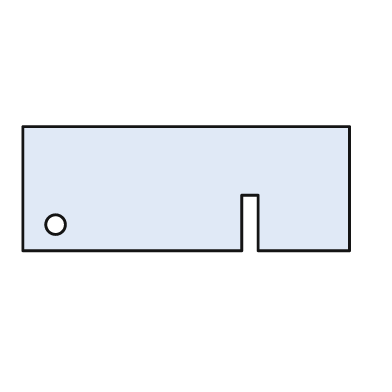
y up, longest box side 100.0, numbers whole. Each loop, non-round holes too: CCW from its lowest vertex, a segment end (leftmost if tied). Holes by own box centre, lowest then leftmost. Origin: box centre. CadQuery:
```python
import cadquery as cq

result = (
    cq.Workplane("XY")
    .moveTo(-50.0, -19.0)
    .lineTo(17.0, -19.0)
    .lineTo(17.0, -2.0)
    .lineTo(22.0, -2.0)
    .lineTo(22.0, -19.0)
    .lineTo(50.0, -19.0)
    .lineTo(50.0, 19.0)
    .lineTo(-50.0, 19.0)
    .close()
    .moveTo(-40.0, -11.0)
    .circle(3.0)
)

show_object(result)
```